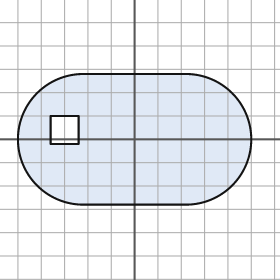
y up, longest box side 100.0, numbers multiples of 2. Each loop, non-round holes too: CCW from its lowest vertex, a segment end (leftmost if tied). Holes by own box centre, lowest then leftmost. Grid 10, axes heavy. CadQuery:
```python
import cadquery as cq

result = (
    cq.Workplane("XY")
    .moveTo(-22.0, -28.0)
    .lineTo(22.0, -28.0)
    .threePointArc((50.0, 0.0), (22.0, 28.0))
    .lineTo(-22.0, 28.0)
    .threePointArc((-50.0, 0.0), (-22.0, -28.0))
    .close()
    .moveTo(-36.0, -2.0)
    .lineTo(-24.0, -2.0)
    .lineTo(-24.0, 10.0)
    .lineTo(-36.0, 10.0)
    .close()
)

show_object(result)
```